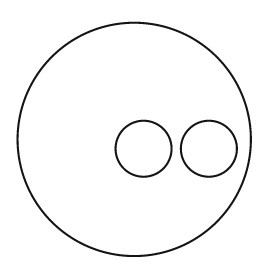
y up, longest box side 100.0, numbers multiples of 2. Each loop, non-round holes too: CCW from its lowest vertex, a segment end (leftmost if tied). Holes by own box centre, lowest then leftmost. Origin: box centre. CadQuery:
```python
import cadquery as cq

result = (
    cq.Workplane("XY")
    .moveTo(0.0, 0.0)
    .circle(50.0)
    .moveTo(4.0, -4.0)
    .circle(12.0)
    .moveTo(32.0, -4.0)
    .circle(12.0)
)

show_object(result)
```